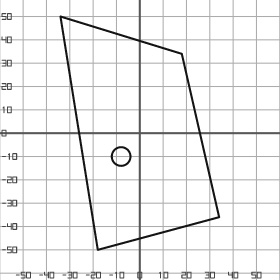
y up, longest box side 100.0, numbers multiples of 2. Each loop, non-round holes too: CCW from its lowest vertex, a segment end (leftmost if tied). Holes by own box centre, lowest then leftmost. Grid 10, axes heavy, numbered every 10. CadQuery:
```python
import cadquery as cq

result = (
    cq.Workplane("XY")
    .moveTo(-18.0, -50.0)
    .lineTo(34.0, -36.0)
    .lineTo(18.0, 34.0)
    .lineTo(-34.0, 50.0)
    .close()
    .moveTo(-8.0, -10.0)
    .circle(4.0)
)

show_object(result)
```